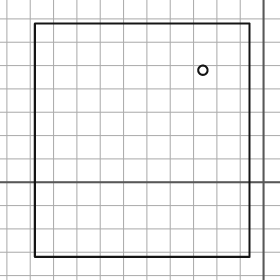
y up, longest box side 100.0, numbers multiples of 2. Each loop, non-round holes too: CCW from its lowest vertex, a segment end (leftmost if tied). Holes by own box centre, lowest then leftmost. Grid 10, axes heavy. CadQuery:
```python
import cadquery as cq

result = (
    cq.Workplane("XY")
    .moveTo(-98.0, -32.0)
    .lineTo(-6.0, -32.0)
    .lineTo(-6.0, 68.0)
    .lineTo(-98.0, 68.0)
    .close()
    .moveTo(-26.0, 48.0)
    .circle(2.0)
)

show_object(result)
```